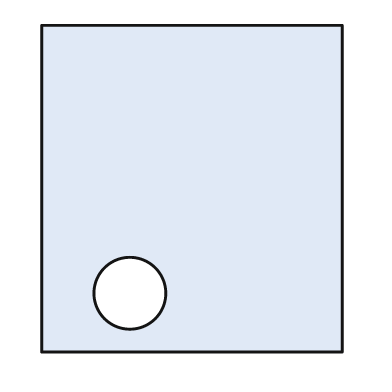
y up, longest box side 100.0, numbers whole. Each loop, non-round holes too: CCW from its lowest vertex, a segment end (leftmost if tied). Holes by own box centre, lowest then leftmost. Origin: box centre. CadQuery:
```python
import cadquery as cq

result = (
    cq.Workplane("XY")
    .moveTo(-46.0, -50.0)
    .lineTo(46.0, -50.0)
    .lineTo(46.0, 50.0)
    .lineTo(-46.0, 50.0)
    .close()
    .moveTo(-19.0, -32.0)
    .circle(11.0)
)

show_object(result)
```